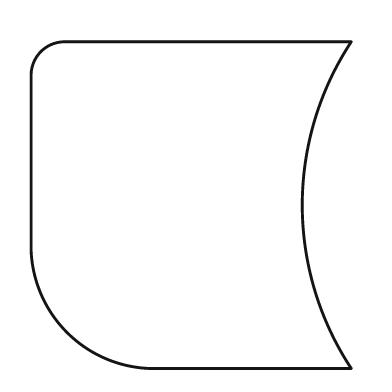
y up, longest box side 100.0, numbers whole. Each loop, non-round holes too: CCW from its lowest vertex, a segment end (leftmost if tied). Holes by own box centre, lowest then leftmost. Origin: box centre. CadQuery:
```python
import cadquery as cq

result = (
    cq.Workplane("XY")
    .moveTo(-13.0, -50.0)
    .lineTo(49.0, -50.0)
    .threePointArc((34.0, 0.0), (49.0, 50.0))
    .lineTo(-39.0, 50.0)
    .threePointArc((-46.0, 47.0), (-49.0, 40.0))
    .lineTo(-49.0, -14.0)
    .threePointArc((-38.0, -39.0), (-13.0, -50.0))
    .close()
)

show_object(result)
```